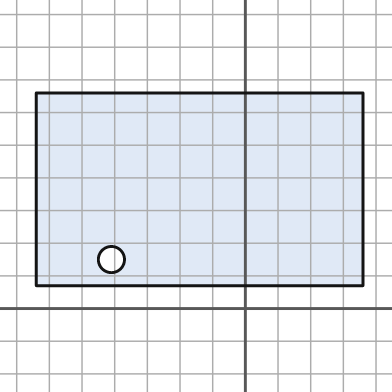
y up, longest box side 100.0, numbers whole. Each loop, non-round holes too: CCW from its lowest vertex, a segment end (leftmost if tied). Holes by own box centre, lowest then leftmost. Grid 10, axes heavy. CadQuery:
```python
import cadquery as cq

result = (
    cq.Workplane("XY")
    .moveTo(-64.0, 7.0)
    .lineTo(36.0, 7.0)
    .lineTo(36.0, 66.0)
    .lineTo(-64.0, 66.0)
    .close()
    .moveTo(-41.0, 15.0)
    .circle(4.0)
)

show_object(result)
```